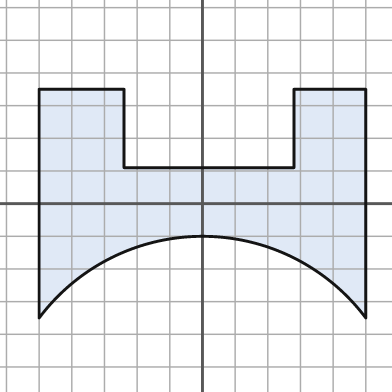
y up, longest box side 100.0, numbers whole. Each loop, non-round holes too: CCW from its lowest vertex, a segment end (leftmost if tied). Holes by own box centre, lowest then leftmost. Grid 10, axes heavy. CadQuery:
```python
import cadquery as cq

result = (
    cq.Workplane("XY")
    .moveTo(-50.0, -35.0)
    .threePointArc((0.0, -10.0), (50.0, -35.0))
    .lineTo(50.0, 35.0)
    .lineTo(28.0, 35.0)
    .lineTo(28.0, 11.0)
    .lineTo(-24.0, 11.0)
    .lineTo(-24.0, 35.0)
    .lineTo(-50.0, 35.0)
    .close()
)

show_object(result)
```